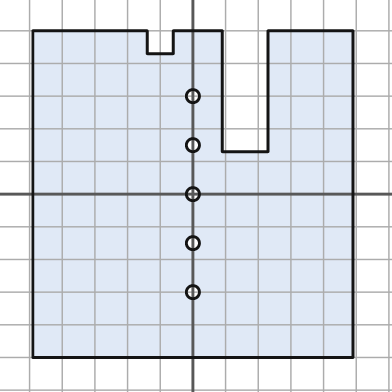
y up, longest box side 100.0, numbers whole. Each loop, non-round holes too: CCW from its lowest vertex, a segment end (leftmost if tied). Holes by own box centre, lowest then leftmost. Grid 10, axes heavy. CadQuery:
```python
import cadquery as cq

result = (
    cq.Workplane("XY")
    .moveTo(-49.0, -50.0)
    .lineTo(49.0, -50.0)
    .lineTo(49.0, 50.0)
    .lineTo(23.0, 50.0)
    .lineTo(23.0, 13.0)
    .lineTo(9.0, 13.0)
    .lineTo(9.0, 50.0)
    .lineTo(-6.0, 50.0)
    .lineTo(-6.0, 43.0)
    .lineTo(-14.0, 43.0)
    .lineTo(-14.0, 50.0)
    .lineTo(-49.0, 50.0)
    .close()
    .moveTo(0.0, -30.0)
    .circle(2.0)
    .moveTo(0.0, -15.0)
    .circle(2.0)
    .moveTo(0.0, 0.0)
    .circle(2.0)
    .moveTo(0.0, 15.0)
    .circle(2.0)
    .moveTo(0.0, 30.0)
    .circle(2.0)
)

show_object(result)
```